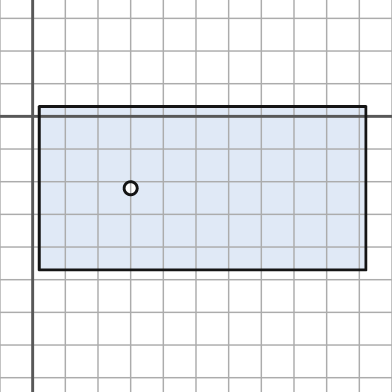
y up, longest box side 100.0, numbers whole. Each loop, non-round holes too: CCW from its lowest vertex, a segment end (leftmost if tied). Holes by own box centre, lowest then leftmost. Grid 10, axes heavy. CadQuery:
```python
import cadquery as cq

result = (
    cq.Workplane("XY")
    .moveTo(2.0, -47.0)
    .lineTo(102.0, -47.0)
    .lineTo(102.0, 3.0)
    .lineTo(2.0, 3.0)
    .close()
    .moveTo(30.0, -22.0)
    .circle(2.0)
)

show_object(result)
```